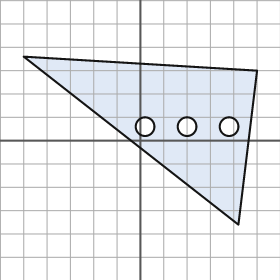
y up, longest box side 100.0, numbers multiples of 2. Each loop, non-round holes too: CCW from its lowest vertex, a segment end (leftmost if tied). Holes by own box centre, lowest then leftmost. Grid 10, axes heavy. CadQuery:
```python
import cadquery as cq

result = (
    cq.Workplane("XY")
    .moveTo(42.0, -36.0)
    .lineTo(50.0, 30.0)
    .lineTo(-50.0, 36.0)
    .close()
    .moveTo(2.0, 6.0)
    .circle(4.0)
    .moveTo(20.0, 6.0)
    .circle(4.0)
    .moveTo(38.0, 6.0)
    .circle(4.0)
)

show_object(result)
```